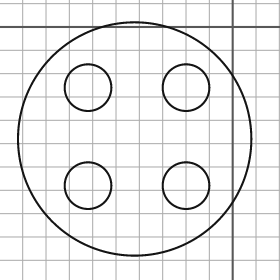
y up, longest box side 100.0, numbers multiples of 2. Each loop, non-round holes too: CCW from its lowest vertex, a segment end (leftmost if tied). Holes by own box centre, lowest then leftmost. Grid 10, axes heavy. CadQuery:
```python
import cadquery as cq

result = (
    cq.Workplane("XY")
    .moveTo(-42.0, -48.0)
    .circle(50.0)
    .moveTo(-62.0, -68.0)
    .circle(10.0)
    .moveTo(-20.0, -68.0)
    .circle(10.0)
    .moveTo(-62.0, -26.0)
    .circle(10.0)
    .moveTo(-20.0, -26.0)
    .circle(10.0)
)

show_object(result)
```